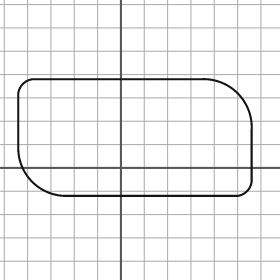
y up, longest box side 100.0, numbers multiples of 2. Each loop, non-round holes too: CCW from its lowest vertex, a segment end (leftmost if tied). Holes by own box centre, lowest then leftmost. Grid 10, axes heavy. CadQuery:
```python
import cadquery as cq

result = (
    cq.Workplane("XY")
    .moveTo(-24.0, -12.0)
    .lineTo(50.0, -12.0)
    .threePointArc((54.0, -10.0), (56.0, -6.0))
    .lineTo(56.0, 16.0)
    .threePointArc((50.0, 32.0), (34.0, 38.0))
    .lineTo(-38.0, 38.0)
    .threePointArc((-42.0, 36.0), (-44.0, 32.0))
    .lineTo(-44.0, 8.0)
    .threePointArc((-38.0, -6.0), (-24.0, -12.0))
    .close()
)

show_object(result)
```